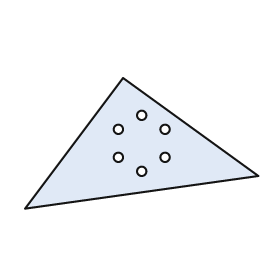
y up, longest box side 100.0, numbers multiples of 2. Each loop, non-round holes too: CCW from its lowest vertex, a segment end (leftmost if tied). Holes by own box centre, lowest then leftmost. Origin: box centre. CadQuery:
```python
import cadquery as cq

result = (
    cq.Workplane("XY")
    .moveTo(-50.0, -28.0)
    .lineTo(50.0, -14.0)
    .lineTo(-8.0, 28.0)
    .close()
    .moveTo(0.0, -12.0)
    .circle(2.0)
    .moveTo(-10.0, -6.0)
    .circle(2.0)
    .moveTo(10.0, -6.0)
    .circle(2.0)
    .moveTo(-10.0, 6.0)
    .circle(2.0)
    .moveTo(10.0, 6.0)
    .circle(2.0)
    .moveTo(0.0, 12.0)
    .circle(2.0)
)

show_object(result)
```